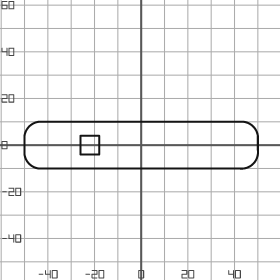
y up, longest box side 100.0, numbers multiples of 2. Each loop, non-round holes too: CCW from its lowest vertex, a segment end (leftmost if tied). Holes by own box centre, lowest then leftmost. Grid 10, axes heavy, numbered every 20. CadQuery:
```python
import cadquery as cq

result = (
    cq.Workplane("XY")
    .moveTo(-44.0, -10.0)
    .lineTo(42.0, -10.0)
    .threePointArc((48.0, -8.0), (50.0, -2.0))
    .lineTo(50.0, 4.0)
    .threePointArc((48.0, 8.0), (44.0, 10.0))
    .lineTo(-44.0, 10.0)
    .threePointArc((-48.0, 8.0), (-50.0, 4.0))
    .lineTo(-50.0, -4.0)
    .threePointArc((-48.0, -8.0), (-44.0, -10.0))
    .close()
    .moveTo(-26.0, -4.0)
    .lineTo(-18.0, -4.0)
    .lineTo(-18.0, 4.0)
    .lineTo(-26.0, 4.0)
    .close()
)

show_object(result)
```